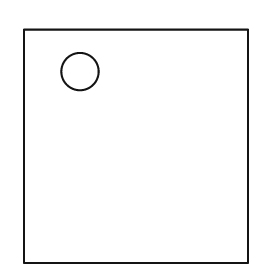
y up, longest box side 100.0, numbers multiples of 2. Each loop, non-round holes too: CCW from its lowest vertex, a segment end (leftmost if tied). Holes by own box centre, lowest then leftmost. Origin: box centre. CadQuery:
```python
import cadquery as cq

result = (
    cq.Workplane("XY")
    .moveTo(-48.0, -50.0)
    .lineTo(48.0, -50.0)
    .lineTo(48.0, 50.0)
    .lineTo(-48.0, 50.0)
    .close()
    .moveTo(-24.0, 32.0)
    .circle(8.0)
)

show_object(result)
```